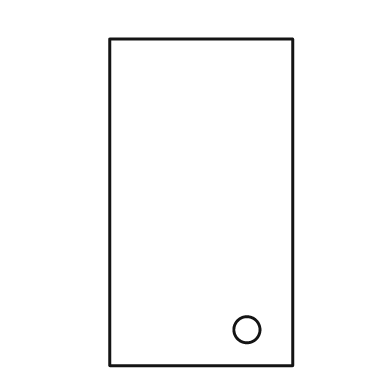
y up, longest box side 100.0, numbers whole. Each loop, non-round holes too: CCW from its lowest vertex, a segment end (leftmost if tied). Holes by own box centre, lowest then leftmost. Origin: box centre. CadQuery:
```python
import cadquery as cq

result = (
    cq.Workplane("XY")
    .moveTo(-28.0, -50.0)
    .lineTo(28.0, -50.0)
    .lineTo(28.0, 50.0)
    .lineTo(-28.0, 50.0)
    .close()
    .moveTo(14.0, -39.0)
    .circle(4.0)
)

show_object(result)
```